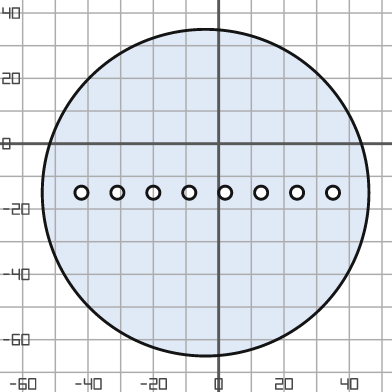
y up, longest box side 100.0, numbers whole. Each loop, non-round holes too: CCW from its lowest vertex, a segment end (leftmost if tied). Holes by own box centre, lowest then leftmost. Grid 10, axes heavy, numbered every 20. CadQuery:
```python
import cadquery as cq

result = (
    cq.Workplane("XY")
    .moveTo(-4.0, -15.0)
    .circle(50.0)
    .moveTo(-42.0, -15.0)
    .circle(2.0)
    .moveTo(-31.0, -15.0)
    .circle(2.0)
    .moveTo(-20.0, -15.0)
    .circle(2.0)
    .moveTo(-9.0, -15.0)
    .circle(2.0)
    .moveTo(2.0, -15.0)
    .circle(2.0)
    .moveTo(13.0, -15.0)
    .circle(2.0)
    .moveTo(24.0, -15.0)
    .circle(2.0)
    .moveTo(35.0, -15.0)
    .circle(2.0)
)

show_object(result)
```